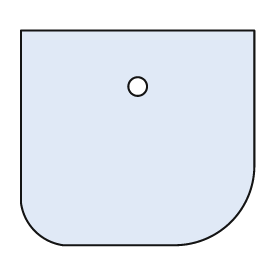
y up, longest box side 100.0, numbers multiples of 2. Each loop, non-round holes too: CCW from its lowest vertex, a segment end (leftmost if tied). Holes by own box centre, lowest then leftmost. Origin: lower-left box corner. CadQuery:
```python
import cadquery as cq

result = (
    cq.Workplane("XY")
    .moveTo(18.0, 0.0)
    .lineTo(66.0, 0.0)
    .threePointArc((90.0, 10.0), (100.0, 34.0))
    .lineTo(100.0, 92.0)
    .lineTo(0.0, 92.0)
    .lineTo(0.0, 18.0)
    .threePointArc((6.0, 6.0), (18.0, 0.0))
    .close()
    .moveTo(50.0, 68.0)
    .circle(4.0)
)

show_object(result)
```